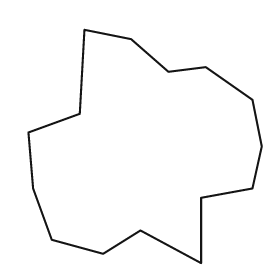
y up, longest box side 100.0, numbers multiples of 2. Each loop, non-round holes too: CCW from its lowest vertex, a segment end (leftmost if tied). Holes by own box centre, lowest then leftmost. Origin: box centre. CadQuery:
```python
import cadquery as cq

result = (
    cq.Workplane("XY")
    .moveTo(24.0, -50.0)
    .lineTo(24.0, -22.0)
    .lineTo(46.0, -18.0)
    .lineTo(50.0, 0.0)
    .lineTo(46.0, 20.0)
    .lineTo(26.0, 34.0)
    .lineTo(10.0, 32.0)
    .lineTo(-6.0, 46.0)
    .lineTo(-26.0, 50.0)
    .lineTo(-28.0, 14.0)
    .lineTo(-50.0, 6.0)
    .lineTo(-48.0, -18.0)
    .lineTo(-40.0, -40.0)
    .lineTo(-18.0, -46.0)
    .lineTo(-2.0, -36.0)
    .close()
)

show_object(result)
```